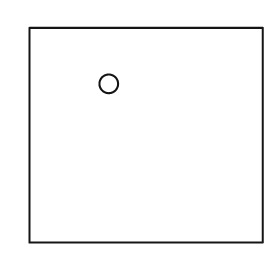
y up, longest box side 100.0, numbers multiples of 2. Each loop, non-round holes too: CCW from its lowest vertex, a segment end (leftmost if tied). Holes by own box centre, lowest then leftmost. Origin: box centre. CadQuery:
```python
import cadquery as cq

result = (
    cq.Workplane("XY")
    .moveTo(-50.0, -46.0)
    .lineTo(50.0, -46.0)
    .lineTo(50.0, 46.0)
    .lineTo(-50.0, 46.0)
    .close()
    .moveTo(-16.0, 22.0)
    .circle(4.0)
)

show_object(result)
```